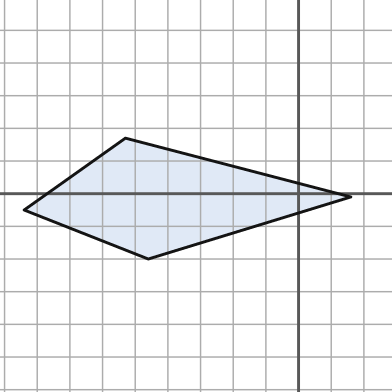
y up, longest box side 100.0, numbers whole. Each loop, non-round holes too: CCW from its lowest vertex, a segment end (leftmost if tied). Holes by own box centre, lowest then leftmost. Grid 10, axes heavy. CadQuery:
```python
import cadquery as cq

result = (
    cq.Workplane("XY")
    .moveTo(-46.0, -20.0)
    .lineTo(16.0, -1.0)
    .lineTo(-53.0, 17.0)
    .lineTo(-84.0, -5.0)
    .close()
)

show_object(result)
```